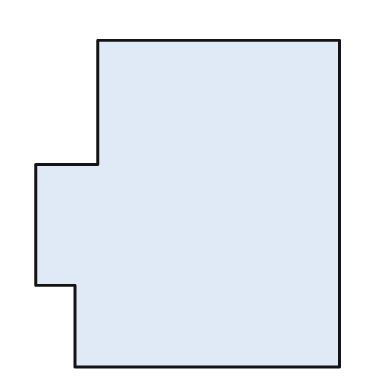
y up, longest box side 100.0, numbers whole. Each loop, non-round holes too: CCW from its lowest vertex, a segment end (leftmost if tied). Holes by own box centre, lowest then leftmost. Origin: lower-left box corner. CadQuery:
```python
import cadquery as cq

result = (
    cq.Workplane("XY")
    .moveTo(12.0, 0.0)
    .lineTo(93.0, 0.0)
    .lineTo(93.0, 100.0)
    .lineTo(19.0, 100.0)
    .lineTo(19.0, 62.0)
    .lineTo(0.0, 62.0)
    .lineTo(0.0, 25.0)
    .lineTo(12.0, 25.0)
    .close()
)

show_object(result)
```